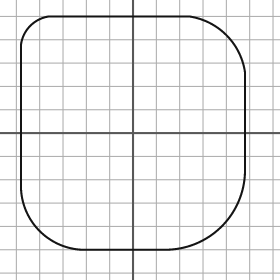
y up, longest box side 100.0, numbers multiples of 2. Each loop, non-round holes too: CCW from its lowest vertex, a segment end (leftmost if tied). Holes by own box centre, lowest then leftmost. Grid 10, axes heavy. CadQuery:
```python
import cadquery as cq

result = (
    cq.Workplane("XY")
    .moveTo(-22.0, -50.0)
    .lineTo(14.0, -50.0)
    .threePointArc((38.0, -40.0), (48.0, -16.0))
    .lineTo(48.0, 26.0)
    .threePointArc((40.0, 42.0), (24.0, 50.0))
    .lineTo(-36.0, 50.0)
    .threePointArc((-44.0, 46.0), (-48.0, 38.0))
    .lineTo(-48.0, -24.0)
    .threePointArc((-40.0, -42.0), (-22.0, -50.0))
    .close()
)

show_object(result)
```